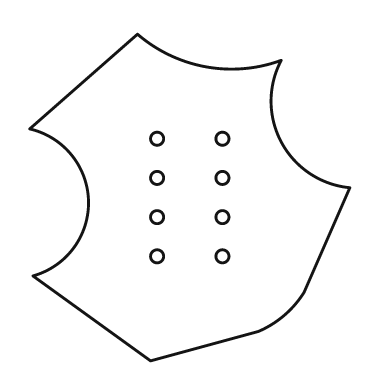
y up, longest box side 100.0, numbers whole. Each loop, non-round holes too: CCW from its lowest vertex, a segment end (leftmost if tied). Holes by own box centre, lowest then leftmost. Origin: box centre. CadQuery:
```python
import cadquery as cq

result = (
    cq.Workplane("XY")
    .moveTo(-12.0, -50.0)
    .lineTo(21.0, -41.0)
    .threePointArc((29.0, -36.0), (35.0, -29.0))
    .lineTo(49.0, 3.0)
    .threePointArc((28.0, 17.0), (28.0, 42.0))
    .threePointArc((5.0, 40.0), (-16.0, 50.0))
    .lineTo(-49.0, 21.0)
    .threePointArc((-31.0, -1.0), (-48.0, -24.0))
    .close()
    .moveTo(-10.0, -18.0)
    .circle(2.0)
    .moveTo(10.0, -18.0)
    .circle(2.0)
    .moveTo(-10.0, -6.0)
    .circle(2.0)
    .moveTo(10.0, -6.0)
    .circle(2.0)
    .moveTo(-10.0, 6.0)
    .circle(2.0)
    .moveTo(10.0, 6.0)
    .circle(2.0)
    .moveTo(-10.0, 18.0)
    .circle(2.0)
    .moveTo(10.0, 18.0)
    .circle(2.0)
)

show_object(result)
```